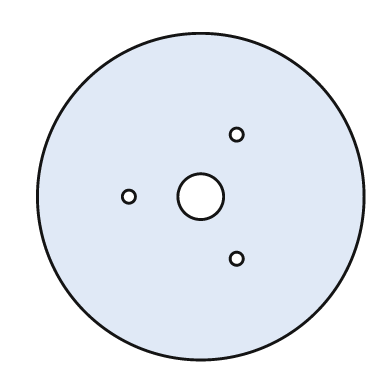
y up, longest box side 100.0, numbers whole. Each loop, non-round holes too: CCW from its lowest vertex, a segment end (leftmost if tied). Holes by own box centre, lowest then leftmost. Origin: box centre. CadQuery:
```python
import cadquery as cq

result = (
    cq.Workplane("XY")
    .moveTo(0.0, 0.0)
    .circle(50.0)
    .moveTo(11.0, -19.0)
    .circle(2.0)
    .moveTo(-22.0, 0.0)
    .circle(2.0)
    .moveTo(0.0, 0.0)
    .circle(7.0)
    .moveTo(11.0, 19.0)
    .circle(2.0)
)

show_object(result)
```